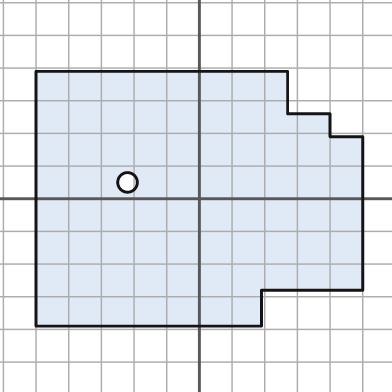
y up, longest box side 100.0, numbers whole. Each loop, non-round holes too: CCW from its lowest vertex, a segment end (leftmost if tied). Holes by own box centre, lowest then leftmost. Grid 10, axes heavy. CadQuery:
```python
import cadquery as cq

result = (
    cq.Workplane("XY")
    .moveTo(-50.0, -39.0)
    .lineTo(19.0, -39.0)
    .lineTo(19.0, -28.0)
    .lineTo(50.0, -28.0)
    .lineTo(50.0, 19.0)
    .lineTo(40.0, 19.0)
    .lineTo(40.0, 26.0)
    .lineTo(27.0, 26.0)
    .lineTo(27.0, 39.0)
    .lineTo(-50.0, 39.0)
    .close()
    .moveTo(-22.0, 5.0)
    .circle(3.0)
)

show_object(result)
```